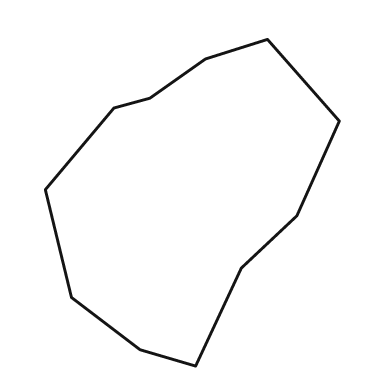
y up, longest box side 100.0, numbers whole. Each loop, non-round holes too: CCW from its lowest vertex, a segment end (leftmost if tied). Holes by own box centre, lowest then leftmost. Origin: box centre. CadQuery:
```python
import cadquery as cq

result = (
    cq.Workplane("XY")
    .moveTo(1.0, -50.0)
    .lineTo(15.0, -20.0)
    .lineTo(32.0, -4.0)
    .lineTo(45.0, 25.0)
    .lineTo(23.0, 50.0)
    .lineTo(4.0, 44.0)
    .lineTo(-13.0, 32.0)
    .lineTo(-24.0, 29.0)
    .lineTo(-45.0, 4.0)
    .lineTo(-37.0, -29.0)
    .lineTo(-16.0, -45.0)
    .close()
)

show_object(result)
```